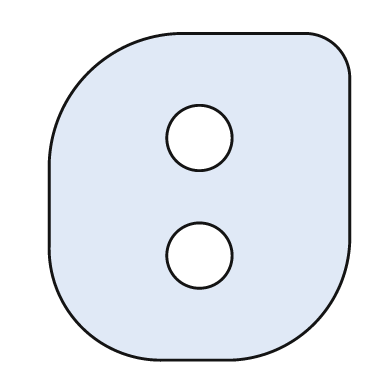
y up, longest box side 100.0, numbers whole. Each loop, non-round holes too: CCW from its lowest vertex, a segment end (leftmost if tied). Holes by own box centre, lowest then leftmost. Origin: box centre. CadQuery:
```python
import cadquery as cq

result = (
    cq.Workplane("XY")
    .moveTo(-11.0, -50.0)
    .lineTo(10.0, -50.0)
    .threePointArc((35.0, -39.0), (46.0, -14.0))
    .lineTo(46.0, 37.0)
    .threePointArc((42.0, 46.0), (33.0, 50.0))
    .lineTo(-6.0, 50.0)
    .threePointArc((-34.0, 38.0), (-46.0, 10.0))
    .lineTo(-46.0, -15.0)
    .threePointArc((-36.0, -40.0), (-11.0, -50.0))
    .close()
    .moveTo(0.0, -18.0)
    .circle(10.0)
    .moveTo(0.0, 18.0)
    .circle(10.0)
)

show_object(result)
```